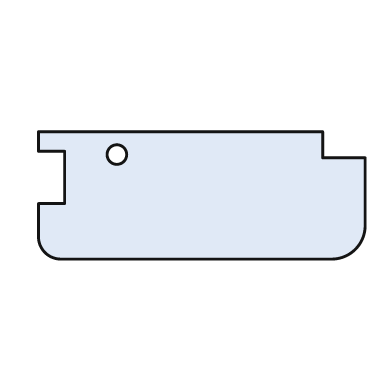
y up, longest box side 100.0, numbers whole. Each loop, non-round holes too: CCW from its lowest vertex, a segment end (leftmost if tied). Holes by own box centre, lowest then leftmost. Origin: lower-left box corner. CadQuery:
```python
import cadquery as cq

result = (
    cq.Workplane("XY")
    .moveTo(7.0, 0.0)
    .lineTo(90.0, 0.0)
    .threePointArc((97.0, 3.0), (100.0, 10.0))
    .lineTo(100.0, 31.0)
    .lineTo(87.0, 31.0)
    .lineTo(87.0, 39.0)
    .lineTo(0.0, 39.0)
    .lineTo(0.0, 33.0)
    .lineTo(8.0, 33.0)
    .lineTo(8.0, 17.0)
    .lineTo(0.0, 17.0)
    .lineTo(0.0, 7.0)
    .threePointArc((2.0, 2.0), (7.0, 0.0))
    .close()
    .moveTo(24.0, 32.0)
    .circle(3.0)
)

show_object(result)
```